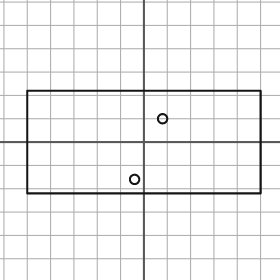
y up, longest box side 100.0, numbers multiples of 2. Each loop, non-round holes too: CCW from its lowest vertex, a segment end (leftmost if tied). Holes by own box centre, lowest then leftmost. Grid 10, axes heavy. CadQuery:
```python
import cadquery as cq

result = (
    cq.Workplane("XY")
    .moveTo(-50.0, -22.0)
    .lineTo(50.0, -22.0)
    .lineTo(50.0, 22.0)
    .lineTo(-50.0, 22.0)
    .close()
    .moveTo(-4.0, -16.0)
    .circle(2.0)
    .moveTo(8.0, 10.0)
    .circle(2.0)
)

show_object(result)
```